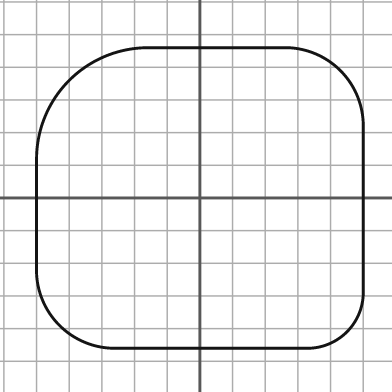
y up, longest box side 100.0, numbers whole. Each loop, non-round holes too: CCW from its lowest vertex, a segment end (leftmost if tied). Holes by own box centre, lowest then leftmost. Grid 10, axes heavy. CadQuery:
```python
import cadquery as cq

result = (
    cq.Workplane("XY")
    .moveTo(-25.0, -46.0)
    .lineTo(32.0, -46.0)
    .threePointArc((45.0, -41.0), (50.0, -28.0))
    .lineTo(50.0, 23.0)
    .threePointArc((43.0, 39.0), (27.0, 46.0))
    .lineTo(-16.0, 46.0)
    .threePointArc((-40.0, 36.0), (-50.0, 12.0))
    .lineTo(-50.0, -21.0)
    .threePointArc((-43.0, -39.0), (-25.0, -46.0))
    .close()
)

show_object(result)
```